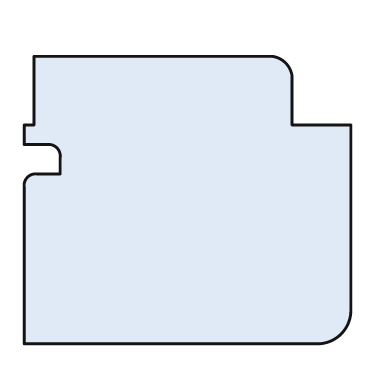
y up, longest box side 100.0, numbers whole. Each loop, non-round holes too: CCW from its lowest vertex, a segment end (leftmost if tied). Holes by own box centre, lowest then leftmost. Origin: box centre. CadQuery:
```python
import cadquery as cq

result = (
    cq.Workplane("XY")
    .moveTo(-50.0, -44.0)
    .lineTo(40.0, -44.0)
    .threePointArc((47.0, -41.0), (50.0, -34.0))
    .lineTo(50.0, 23.0)
    .lineTo(32.0, 23.0)
    .lineTo(32.0, 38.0)
    .threePointArc((30.0, 42.0), (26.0, 44.0))
    .lineTo(-47.0, 44.0)
    .lineTo(-47.0, 23.0)
    .lineTo(-50.0, 23.0)
    .lineTo(-50.0, 17.0)
    .lineTo(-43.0, 17.0)
    .threePointArc((-40.0, 16.0), (-39.0, 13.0))
    .lineTo(-39.0, 8.0)
    .lineTo(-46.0, 8.0)
    .threePointArc((-49.0, 7.0), (-50.0, 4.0))
    .close()
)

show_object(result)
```